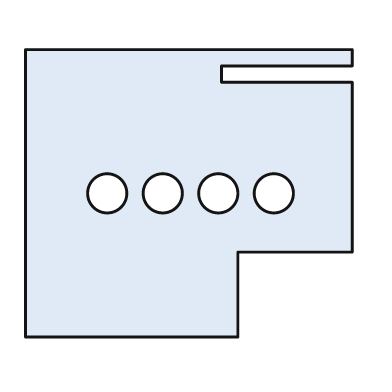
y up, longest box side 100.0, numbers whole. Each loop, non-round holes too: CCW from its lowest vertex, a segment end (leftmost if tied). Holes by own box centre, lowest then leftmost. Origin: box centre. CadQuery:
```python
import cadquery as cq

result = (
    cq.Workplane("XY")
    .moveTo(-50.0, -44.0)
    .lineTo(15.0, -44.0)
    .lineTo(15.0, -18.0)
    .lineTo(50.0, -18.0)
    .lineTo(50.0, 34.0)
    .lineTo(10.0, 34.0)
    .lineTo(10.0, 39.0)
    .lineTo(50.0, 39.0)
    .lineTo(50.0, 44.0)
    .lineTo(-50.0, 44.0)
    .close()
    .moveTo(-25.0, 0.0)
    .circle(6.0)
    .moveTo(-8.0, 0.0)
    .circle(6.0)
    .moveTo(9.0, 0.0)
    .circle(6.0)
    .moveTo(26.0, 0.0)
    .circle(6.0)
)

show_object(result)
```